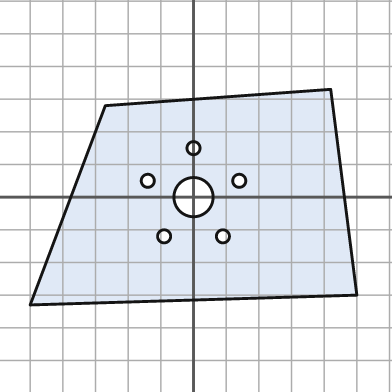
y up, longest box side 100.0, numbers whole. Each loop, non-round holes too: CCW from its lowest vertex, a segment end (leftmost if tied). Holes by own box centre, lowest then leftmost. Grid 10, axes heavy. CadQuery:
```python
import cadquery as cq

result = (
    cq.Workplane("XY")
    .moveTo(-50.0, -33.0)
    .lineTo(50.0, -30.0)
    .lineTo(42.0, 33.0)
    .lineTo(-27.0, 28.0)
    .close()
    .moveTo(-9.0, -12.0)
    .circle(2.0)
    .moveTo(9.0, -12.0)
    .circle(2.0)
    .moveTo(0.0, 0.0)
    .circle(6.0)
    .moveTo(-14.0, 5.0)
    .circle(2.0)
    .moveTo(14.0, 5.0)
    .circle(2.0)
    .moveTo(0.0, 15.0)
    .circle(2.0)
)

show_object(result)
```